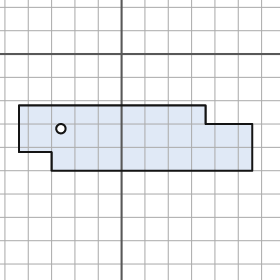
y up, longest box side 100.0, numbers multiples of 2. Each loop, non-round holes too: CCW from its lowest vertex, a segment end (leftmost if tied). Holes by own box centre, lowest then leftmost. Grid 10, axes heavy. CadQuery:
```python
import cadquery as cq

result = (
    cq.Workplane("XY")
    .moveTo(-30.0, -50.0)
    .lineTo(56.0, -50.0)
    .lineTo(56.0, -30.0)
    .lineTo(36.0, -30.0)
    .lineTo(36.0, -22.0)
    .lineTo(-44.0, -22.0)
    .lineTo(-44.0, -42.0)
    .lineTo(-30.0, -42.0)
    .close()
    .moveTo(-26.0, -32.0)
    .circle(2.0)
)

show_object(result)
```